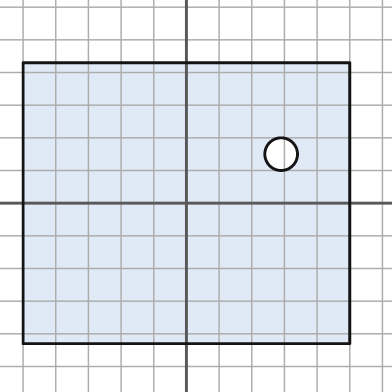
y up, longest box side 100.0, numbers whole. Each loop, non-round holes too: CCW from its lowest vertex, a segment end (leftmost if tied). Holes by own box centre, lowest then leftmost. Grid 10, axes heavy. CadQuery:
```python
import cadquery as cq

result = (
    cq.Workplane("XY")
    .moveTo(-50.0, -43.0)
    .lineTo(50.0, -43.0)
    .lineTo(50.0, 43.0)
    .lineTo(-50.0, 43.0)
    .close()
    .moveTo(29.0, 15.0)
    .circle(5.0)
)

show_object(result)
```